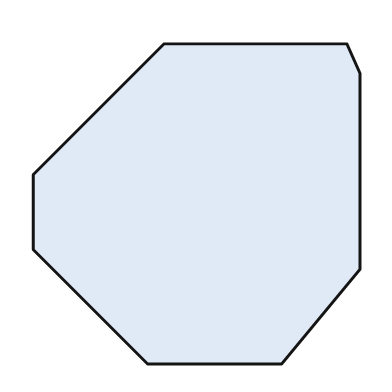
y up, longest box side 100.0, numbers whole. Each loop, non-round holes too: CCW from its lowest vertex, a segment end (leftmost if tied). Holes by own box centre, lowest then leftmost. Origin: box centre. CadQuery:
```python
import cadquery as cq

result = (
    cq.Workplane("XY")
    .moveTo(-15.0, -49.0)
    .lineTo(26.0, -49.0)
    .lineTo(50.0, -20.0)
    .lineTo(50.0, 40.0)
    .lineTo(46.0, 49.0)
    .lineTo(-10.0, 49.0)
    .lineTo(-50.0, 9.0)
    .lineTo(-50.0, -14.0)
    .close()
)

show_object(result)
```